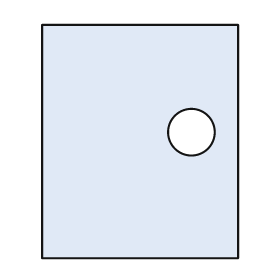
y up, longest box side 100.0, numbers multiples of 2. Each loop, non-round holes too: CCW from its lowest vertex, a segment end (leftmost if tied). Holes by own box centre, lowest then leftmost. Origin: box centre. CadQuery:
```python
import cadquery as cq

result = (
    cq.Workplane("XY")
    .moveTo(-42.0, -50.0)
    .lineTo(42.0, -50.0)
    .lineTo(42.0, 50.0)
    .lineTo(-42.0, 50.0)
    .close()
    .moveTo(22.0, 4.0)
    .circle(10.0)
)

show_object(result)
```